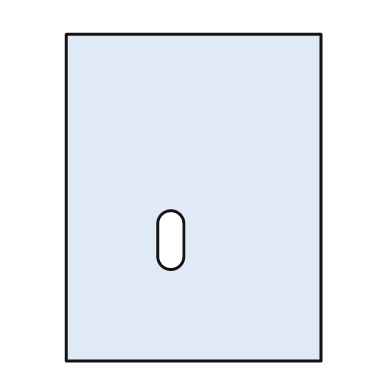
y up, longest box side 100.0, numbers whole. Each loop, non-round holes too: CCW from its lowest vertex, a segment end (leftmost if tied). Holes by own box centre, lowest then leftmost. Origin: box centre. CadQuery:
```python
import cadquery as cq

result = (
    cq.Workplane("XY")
    .moveTo(-39.0, -50.0)
    .lineTo(39.0, -50.0)
    .lineTo(39.0, 50.0)
    .lineTo(-39.0, 50.0)
    .close()
    .moveTo(-11.0, -18.0)
    .threePointArc((-7.0, -22.0), (-3.0, -18.0))
    .lineTo(-3.0, -8.0)
    .threePointArc((-7.0, -4.0), (-11.0, -8.0))
    .close()
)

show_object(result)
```